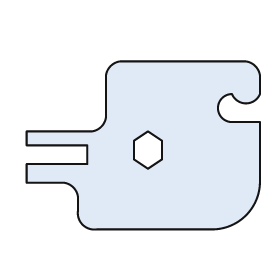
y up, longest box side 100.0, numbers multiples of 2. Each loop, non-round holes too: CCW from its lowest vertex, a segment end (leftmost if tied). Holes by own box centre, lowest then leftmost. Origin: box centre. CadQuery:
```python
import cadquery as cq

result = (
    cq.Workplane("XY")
    .moveTo(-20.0, -36.0)
    .lineTo(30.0, -36.0)
    .threePointArc((44.0, -30.0), (50.0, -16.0))
    .lineTo(50.0, 10.0)
    .lineTo(38.0, 10.0)
    .threePointArc((32.0, 16.0), (38.0, 22.0))
    .threePointArc((44.0, 18.0), (50.0, 22.0))
    .lineTo(50.0, 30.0)
    .threePointArc((48.0, 34.0), (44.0, 36.0))
    .lineTo(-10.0, 36.0)
    .threePointArc((-14.0, 34.0), (-16.0, 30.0))
    .lineTo(-16.0, 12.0)
    .threePointArc((-18.0, 8.0), (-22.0, 6.0))
    .lineTo(-50.0, 6.0)
    .lineTo(-50.0, 0.0)
    .lineTo(-24.0, 0.0)
    .lineTo(-24.0, -8.0)
    .lineTo(-50.0, -8.0)
    .lineTo(-50.0, -16.0)
    .lineTo(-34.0, -16.0)
    .threePointArc((-30.0, -18.0), (-28.0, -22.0))
    .lineTo(-28.0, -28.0)
    .threePointArc((-26.0, -34.0), (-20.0, -36.0))
    .close()
    .moveTo(2.0, -10.0)
    .lineTo(8.0, -6.0)
    .lineTo(8.0, 2.0)
    .lineTo(2.0, 6.0)
    .lineTo(-4.0, 2.0)
    .lineTo(-4.0, -6.0)
    .close()
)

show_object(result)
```